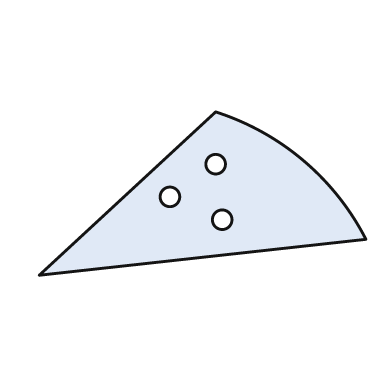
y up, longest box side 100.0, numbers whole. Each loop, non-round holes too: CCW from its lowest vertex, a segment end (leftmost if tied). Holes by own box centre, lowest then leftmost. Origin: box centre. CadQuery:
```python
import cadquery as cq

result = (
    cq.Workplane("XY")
    .moveTo(-50.0, -25.0)
    .lineTo(50.0, -14.0)
    .threePointArc((31.0, 10.0), (4.0, 25.0))
    .close()
    .moveTo(6.0, -8.0)
    .circle(3.0)
    .moveTo(-10.0, -1.0)
    .circle(3.0)
    .moveTo(4.0, 9.0)
    .circle(3.0)
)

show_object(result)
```